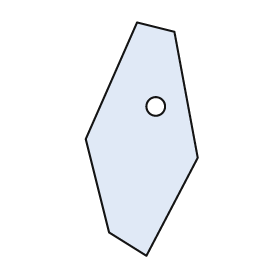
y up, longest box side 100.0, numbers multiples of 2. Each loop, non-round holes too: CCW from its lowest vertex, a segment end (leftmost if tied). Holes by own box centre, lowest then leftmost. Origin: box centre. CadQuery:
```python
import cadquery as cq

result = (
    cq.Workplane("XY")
    .moveTo(2.0, -50.0)
    .lineTo(24.0, -8.0)
    .lineTo(14.0, 46.0)
    .lineTo(-2.0, 50.0)
    .lineTo(-24.0, 0.0)
    .lineTo(-14.0, -40.0)
    .close()
    .moveTo(6.0, 14.0)
    .circle(4.0)
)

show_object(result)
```